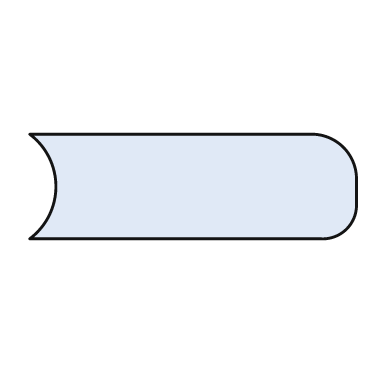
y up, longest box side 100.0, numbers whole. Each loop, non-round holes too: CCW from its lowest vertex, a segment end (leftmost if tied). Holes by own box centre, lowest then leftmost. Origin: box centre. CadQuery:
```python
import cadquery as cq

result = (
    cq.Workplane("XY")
    .moveTo(-50.0, -16.0)
    .lineTo(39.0, -16.0)
    .threePointArc((47.0, -13.0), (50.0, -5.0))
    .lineTo(50.0, 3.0)
    .threePointArc((46.0, 12.0), (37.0, 16.0))
    .lineTo(-50.0, 16.0)
    .threePointArc((-42.0, 0.0), (-50.0, -16.0))
    .close()
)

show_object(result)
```